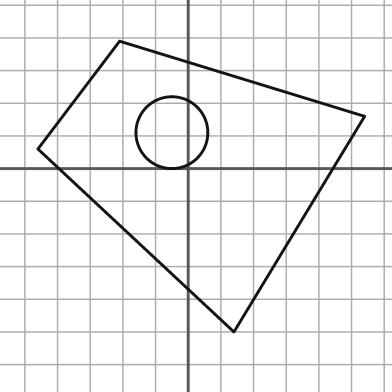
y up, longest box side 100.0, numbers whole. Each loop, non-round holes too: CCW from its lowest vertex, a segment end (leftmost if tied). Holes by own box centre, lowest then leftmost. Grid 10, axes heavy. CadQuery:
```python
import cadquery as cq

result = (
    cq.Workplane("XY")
    .moveTo(14.0, -50.0)
    .lineTo(54.0, 16.0)
    .lineTo(-21.0, 39.0)
    .lineTo(-46.0, 6.0)
    .close()
    .moveTo(-5.0, 11.0)
    .circle(11.0)
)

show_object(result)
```